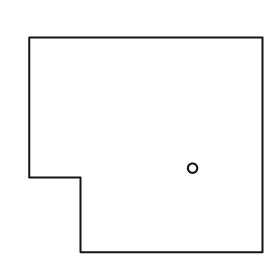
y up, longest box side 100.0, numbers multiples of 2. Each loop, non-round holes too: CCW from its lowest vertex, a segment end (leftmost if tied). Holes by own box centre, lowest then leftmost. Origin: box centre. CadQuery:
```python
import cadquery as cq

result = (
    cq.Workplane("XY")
    .moveTo(-28.0, -46.0)
    .lineTo(50.0, -46.0)
    .lineTo(50.0, 46.0)
    .lineTo(-50.0, 46.0)
    .lineTo(-50.0, -14.0)
    .lineTo(-28.0, -14.0)
    .close()
    .moveTo(20.0, -10.0)
    .circle(2.0)
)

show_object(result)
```